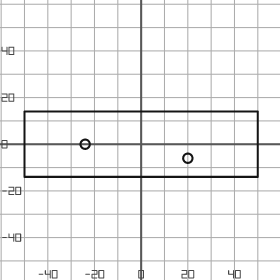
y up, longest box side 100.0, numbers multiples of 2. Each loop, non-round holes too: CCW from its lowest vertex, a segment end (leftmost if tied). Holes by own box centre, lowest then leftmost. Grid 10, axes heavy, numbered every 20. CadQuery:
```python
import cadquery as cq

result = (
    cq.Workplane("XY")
    .moveTo(-50.0, -14.0)
    .lineTo(50.0, -14.0)
    .lineTo(50.0, 14.0)
    .lineTo(-50.0, 14.0)
    .close()
    .moveTo(20.0, -6.0)
    .circle(2.0)
    .moveTo(-24.0, 0.0)
    .circle(2.0)
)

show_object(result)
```